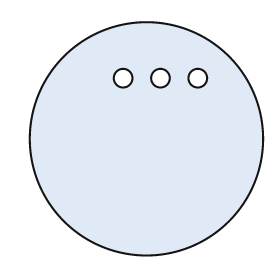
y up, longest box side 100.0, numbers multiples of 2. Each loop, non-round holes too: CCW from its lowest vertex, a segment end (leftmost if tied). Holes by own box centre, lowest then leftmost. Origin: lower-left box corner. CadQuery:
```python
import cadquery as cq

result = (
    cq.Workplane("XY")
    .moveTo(50.0, 50.0)
    .circle(50.0)
    .moveTo(40.0, 76.0)
    .circle(4.0)
    .moveTo(56.0, 76.0)
    .circle(4.0)
    .moveTo(72.0, 76.0)
    .circle(4.0)
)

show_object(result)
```